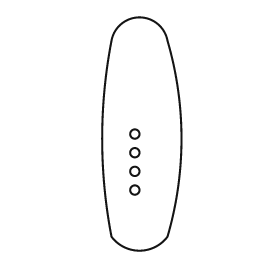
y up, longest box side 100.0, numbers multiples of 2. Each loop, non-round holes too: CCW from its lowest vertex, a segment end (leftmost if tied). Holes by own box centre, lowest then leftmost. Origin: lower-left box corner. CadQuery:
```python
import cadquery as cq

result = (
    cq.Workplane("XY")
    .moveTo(4.0, 6.0)
    .threePointArc((16.0, 0.0), (28.0, 6.0))
    .threePointArc((34.0, 48.0), (28.0, 90.0))
    .threePointArc((16.0, 100.0), (4.0, 90.0))
    .threePointArc((0.0, 48.0), (4.0, 6.0))
    .close()
    .moveTo(14.0, 26.0)
    .circle(2.0)
    .moveTo(14.0, 34.0)
    .circle(2.0)
    .moveTo(14.0, 42.0)
    .circle(2.0)
    .moveTo(14.0, 50.0)
    .circle(2.0)
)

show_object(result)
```